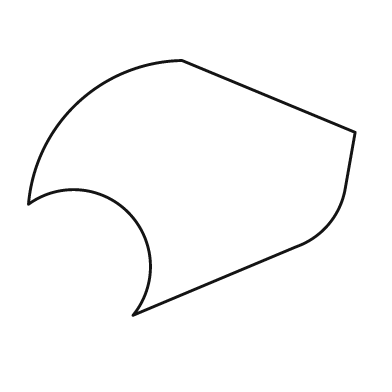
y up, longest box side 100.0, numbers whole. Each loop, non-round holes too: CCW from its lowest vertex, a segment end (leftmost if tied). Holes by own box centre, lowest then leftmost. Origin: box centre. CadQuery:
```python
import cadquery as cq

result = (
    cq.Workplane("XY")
    .moveTo(-18.0, -39.0)
    .lineTo(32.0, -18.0)
    .threePointArc((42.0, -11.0), (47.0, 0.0))
    .lineTo(50.0, 17.0)
    .lineTo(-3.0, 39.0)
    .threePointArc((-35.0, 26.0), (-50.0, -5.0))
    .threePointArc((-19.0, -8.0), (-18.0, -39.0))
    .close()
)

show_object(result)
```